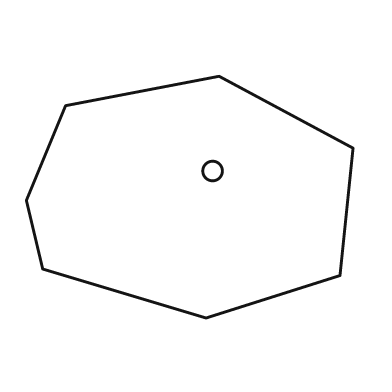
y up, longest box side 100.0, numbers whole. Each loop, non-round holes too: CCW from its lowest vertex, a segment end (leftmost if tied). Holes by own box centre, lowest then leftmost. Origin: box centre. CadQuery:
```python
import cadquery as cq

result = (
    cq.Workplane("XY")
    .moveTo(5.0, -37.0)
    .lineTo(46.0, -24.0)
    .lineTo(50.0, 15.0)
    .lineTo(9.0, 37.0)
    .lineTo(-38.0, 28.0)
    .lineTo(-50.0, -1.0)
    .lineTo(-45.0, -22.0)
    .close()
    .moveTo(7.0, 8.0)
    .circle(3.0)
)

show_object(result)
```